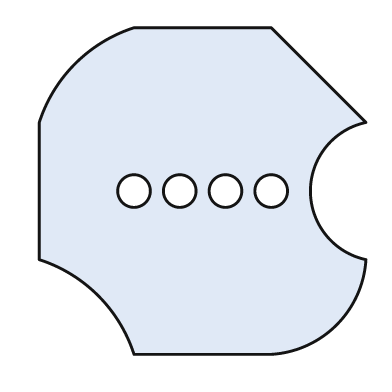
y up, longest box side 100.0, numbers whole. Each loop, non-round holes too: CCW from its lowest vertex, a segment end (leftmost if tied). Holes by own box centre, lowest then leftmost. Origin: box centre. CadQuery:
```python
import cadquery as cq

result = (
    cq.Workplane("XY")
    .moveTo(-21.0, -50.0)
    .lineTo(21.0, -50.0)
    .threePointArc((41.0, -41.0), (50.0, -21.0))
    .threePointArc((33.0, 0.0), (50.0, 21.0))
    .lineTo(21.0, 50.0)
    .lineTo(-21.0, 50.0)
    .threePointArc((-39.0, 39.0), (-50.0, 21.0))
    .lineTo(-50.0, -21.0)
    .threePointArc((-32.0, -32.0), (-21.0, -50.0))
    .close()
    .moveTo(-21.0, 0.0)
    .circle(5.0)
    .moveTo(-7.0, 0.0)
    .circle(5.0)
    .moveTo(7.0, 0.0)
    .circle(5.0)
    .moveTo(21.0, 0.0)
    .circle(5.0)
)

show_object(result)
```